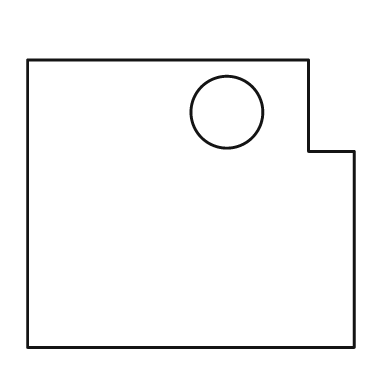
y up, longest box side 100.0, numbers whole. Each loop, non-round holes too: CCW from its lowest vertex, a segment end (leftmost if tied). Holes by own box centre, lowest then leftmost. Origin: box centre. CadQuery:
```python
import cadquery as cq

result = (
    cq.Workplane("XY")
    .moveTo(-50.0, -44.0)
    .lineTo(50.0, -44.0)
    .lineTo(50.0, 16.0)
    .lineTo(36.0, 16.0)
    .lineTo(36.0, 44.0)
    .lineTo(-50.0, 44.0)
    .close()
    .moveTo(11.0, 28.0)
    .circle(11.0)
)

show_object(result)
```